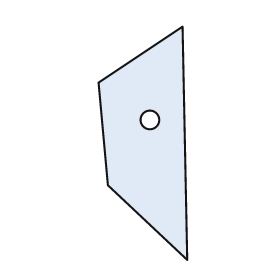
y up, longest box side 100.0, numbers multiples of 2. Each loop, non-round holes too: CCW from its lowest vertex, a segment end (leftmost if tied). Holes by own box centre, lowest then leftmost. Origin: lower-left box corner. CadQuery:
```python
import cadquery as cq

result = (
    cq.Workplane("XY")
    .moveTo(38.0, 0.0)
    .lineTo(36.0, 100.0)
    .lineTo(0.0, 76.0)
    .lineTo(4.0, 32.0)
    .close()
    .moveTo(22.0, 60.0)
    .circle(4.0)
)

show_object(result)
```